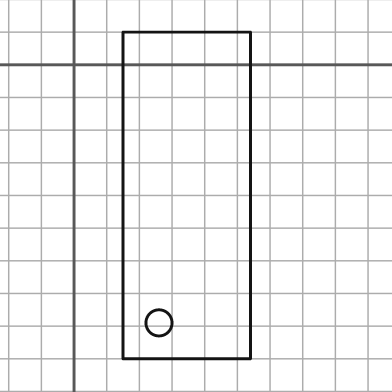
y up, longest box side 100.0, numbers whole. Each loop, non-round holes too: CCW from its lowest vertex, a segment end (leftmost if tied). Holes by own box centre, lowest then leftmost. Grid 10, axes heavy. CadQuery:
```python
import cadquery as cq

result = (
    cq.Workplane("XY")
    .moveTo(15.0, -90.0)
    .lineTo(54.0, -90.0)
    .lineTo(54.0, 10.0)
    .lineTo(15.0, 10.0)
    .close()
    .moveTo(26.0, -79.0)
    .circle(4.0)
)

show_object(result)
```